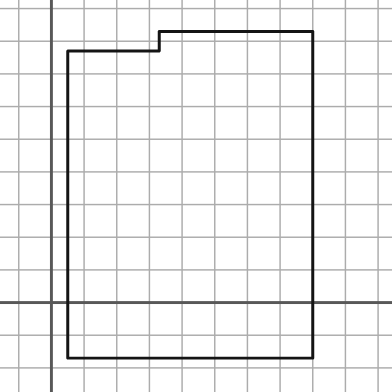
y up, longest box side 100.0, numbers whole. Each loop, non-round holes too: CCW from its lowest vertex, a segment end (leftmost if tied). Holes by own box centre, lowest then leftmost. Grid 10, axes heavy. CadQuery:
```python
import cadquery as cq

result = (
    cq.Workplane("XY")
    .moveTo(5.0, -17.0)
    .lineTo(80.0, -17.0)
    .lineTo(80.0, 83.0)
    .lineTo(33.0, 83.0)
    .lineTo(33.0, 77.0)
    .lineTo(5.0, 77.0)
    .close()
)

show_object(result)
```